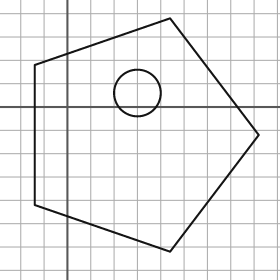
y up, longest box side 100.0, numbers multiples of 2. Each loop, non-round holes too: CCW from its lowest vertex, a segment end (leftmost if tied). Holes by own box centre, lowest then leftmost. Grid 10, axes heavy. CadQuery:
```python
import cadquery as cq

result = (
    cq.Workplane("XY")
    .moveTo(44.0, -62.0)
    .lineTo(82.0, -12.0)
    .lineTo(44.0, 38.0)
    .lineTo(-14.0, 18.0)
    .lineTo(-14.0, -42.0)
    .close()
    .moveTo(30.0, 6.0)
    .circle(10.0)
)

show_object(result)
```